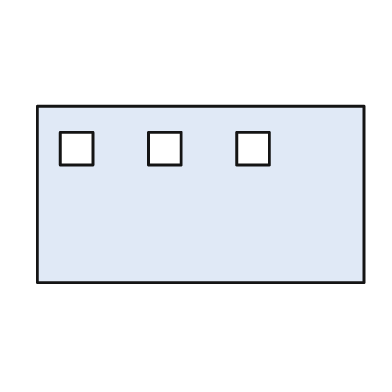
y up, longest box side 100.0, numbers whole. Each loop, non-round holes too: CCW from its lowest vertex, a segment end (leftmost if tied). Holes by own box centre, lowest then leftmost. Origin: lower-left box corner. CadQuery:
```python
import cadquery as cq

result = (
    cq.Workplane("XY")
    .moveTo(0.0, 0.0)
    .lineTo(100.0, 0.0)
    .lineTo(100.0, 54.0)
    .lineTo(0.0, 54.0)
    .close()
    .moveTo(7.0, 36.0)
    .lineTo(17.0, 36.0)
    .lineTo(17.0, 46.0)
    .lineTo(7.0, 46.0)
    .close()
    .moveTo(34.0, 36.0)
    .lineTo(44.0, 36.0)
    .lineTo(44.0, 46.0)
    .lineTo(34.0, 46.0)
    .close()
    .moveTo(61.0, 36.0)
    .lineTo(71.0, 36.0)
    .lineTo(71.0, 46.0)
    .lineTo(61.0, 46.0)
    .close()
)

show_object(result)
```